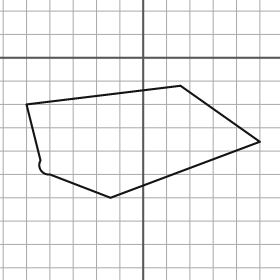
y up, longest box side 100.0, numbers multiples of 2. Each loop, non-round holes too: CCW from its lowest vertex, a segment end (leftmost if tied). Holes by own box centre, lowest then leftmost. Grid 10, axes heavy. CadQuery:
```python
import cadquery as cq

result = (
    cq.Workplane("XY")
    .moveTo(-14.0, -60.0)
    .lineTo(50.0, -36.0)
    .lineTo(16.0, -12.0)
    .lineTo(-50.0, -20.0)
    .lineTo(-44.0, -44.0)
    .threePointArc((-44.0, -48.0), (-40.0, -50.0))
    .close()
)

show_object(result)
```